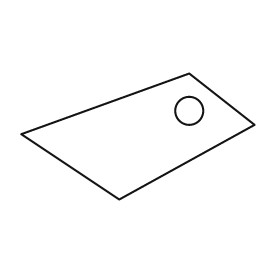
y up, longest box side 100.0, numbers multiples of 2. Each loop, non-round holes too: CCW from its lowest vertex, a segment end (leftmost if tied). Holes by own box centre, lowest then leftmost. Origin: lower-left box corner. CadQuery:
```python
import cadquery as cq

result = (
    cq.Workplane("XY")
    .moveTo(42.0, 0.0)
    .lineTo(100.0, 32.0)
    .lineTo(72.0, 54.0)
    .lineTo(0.0, 28.0)
    .close()
    .moveTo(72.0, 38.0)
    .circle(6.0)
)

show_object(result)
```